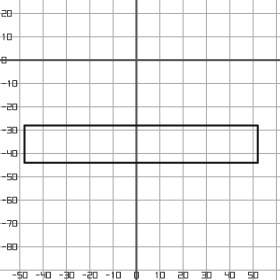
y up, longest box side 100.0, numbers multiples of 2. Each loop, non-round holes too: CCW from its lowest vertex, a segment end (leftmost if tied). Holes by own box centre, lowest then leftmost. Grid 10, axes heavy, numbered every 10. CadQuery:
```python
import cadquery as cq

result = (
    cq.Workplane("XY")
    .moveTo(-48.0, -44.0)
    .lineTo(52.0, -44.0)
    .lineTo(52.0, -28.0)
    .lineTo(-48.0, -28.0)
    .close()
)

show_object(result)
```